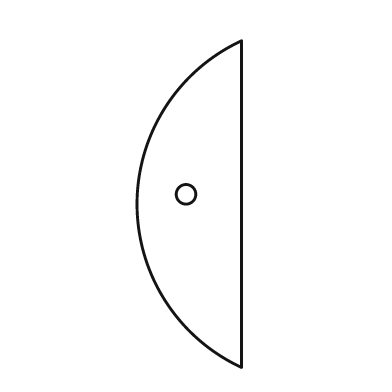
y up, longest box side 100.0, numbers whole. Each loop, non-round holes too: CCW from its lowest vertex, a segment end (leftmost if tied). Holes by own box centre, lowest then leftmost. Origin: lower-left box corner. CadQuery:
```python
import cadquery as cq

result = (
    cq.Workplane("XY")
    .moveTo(32.0, 0.0)
    .lineTo(32.0, 100.0)
    .threePointArc((0.0, 50.0), (32.0, 0.0))
    .close()
    .moveTo(15.0, 53.0)
    .circle(3.0)
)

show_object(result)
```